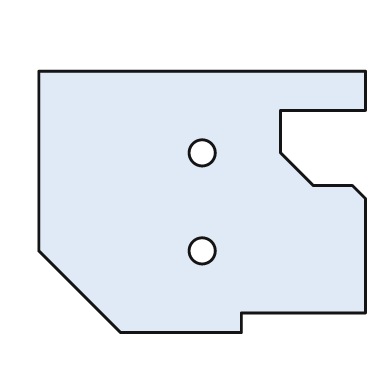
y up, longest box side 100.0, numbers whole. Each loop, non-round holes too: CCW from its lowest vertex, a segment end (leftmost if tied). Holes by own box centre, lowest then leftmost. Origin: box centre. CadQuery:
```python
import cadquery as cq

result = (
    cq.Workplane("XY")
    .moveTo(-25.0, -40.0)
    .lineTo(12.0, -40.0)
    .lineTo(12.0, -34.0)
    .lineTo(50.0, -34.0)
    .lineTo(50.0, 1.0)
    .lineTo(46.0, 5.0)
    .lineTo(34.0, 5.0)
    .lineTo(24.0, 15.0)
    .lineTo(24.0, 28.0)
    .lineTo(50.0, 28.0)
    .lineTo(50.0, 40.0)
    .lineTo(-50.0, 40.0)
    .lineTo(-50.0, -15.0)
    .close()
    .moveTo(0.0, -15.0)
    .circle(4.0)
    .moveTo(0.0, 15.0)
    .circle(4.0)
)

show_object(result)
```